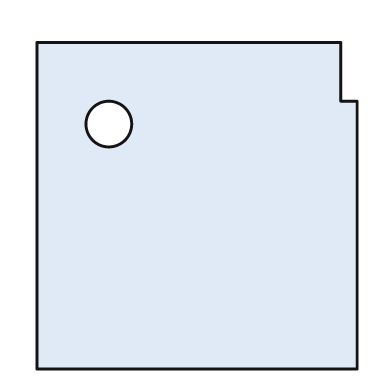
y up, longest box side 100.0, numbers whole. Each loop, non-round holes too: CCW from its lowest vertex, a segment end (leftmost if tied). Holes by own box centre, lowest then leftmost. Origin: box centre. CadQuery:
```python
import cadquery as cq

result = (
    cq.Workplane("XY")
    .moveTo(-49.0, -50.0)
    .lineTo(49.0, -50.0)
    .lineTo(49.0, 32.0)
    .lineTo(44.0, 32.0)
    .lineTo(44.0, 50.0)
    .lineTo(-49.0, 50.0)
    .close()
    .moveTo(-27.0, 25.0)
    .circle(7.0)
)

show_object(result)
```